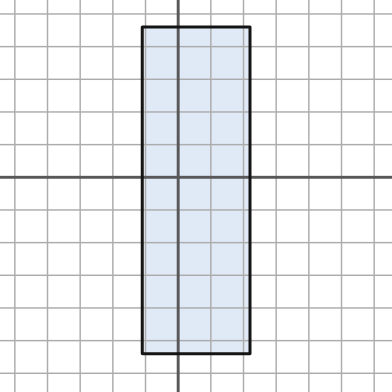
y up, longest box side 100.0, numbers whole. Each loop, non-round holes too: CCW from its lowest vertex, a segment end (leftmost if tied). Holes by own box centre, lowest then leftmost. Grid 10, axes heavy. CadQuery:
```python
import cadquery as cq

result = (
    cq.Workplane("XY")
    .moveTo(-11.0, -54.0)
    .lineTo(22.0, -54.0)
    .lineTo(22.0, 46.0)
    .lineTo(-11.0, 46.0)
    .close()
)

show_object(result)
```